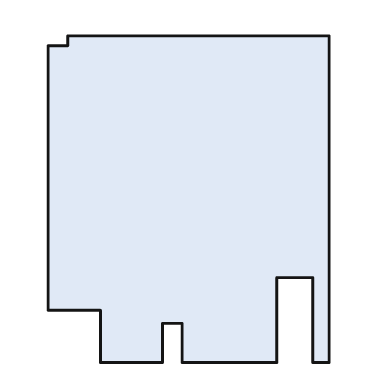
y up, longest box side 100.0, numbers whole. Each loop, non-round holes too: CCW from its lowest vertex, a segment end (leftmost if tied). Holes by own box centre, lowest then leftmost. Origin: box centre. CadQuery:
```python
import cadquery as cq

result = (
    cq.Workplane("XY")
    .moveTo(-27.0, -50.0)
    .lineTo(-8.0, -50.0)
    .lineTo(-8.0, -38.0)
    .lineTo(-2.0, -38.0)
    .lineTo(-2.0, -50.0)
    .lineTo(27.0, -50.0)
    .lineTo(27.0, -24.0)
    .lineTo(38.0, -24.0)
    .lineTo(38.0, -50.0)
    .lineTo(43.0, -50.0)
    .lineTo(43.0, 50.0)
    .lineTo(-37.0, 50.0)
    .lineTo(-37.0, 47.0)
    .lineTo(-43.0, 47.0)
    .lineTo(-43.0, -34.0)
    .lineTo(-27.0, -34.0)
    .close()
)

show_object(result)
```